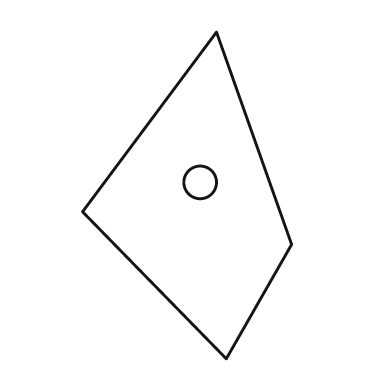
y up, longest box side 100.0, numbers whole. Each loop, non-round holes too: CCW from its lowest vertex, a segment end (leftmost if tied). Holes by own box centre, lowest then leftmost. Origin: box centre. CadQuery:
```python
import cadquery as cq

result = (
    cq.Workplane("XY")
    .moveTo(12.0, -50.0)
    .lineTo(32.0, -15.0)
    .lineTo(9.0, 50.0)
    .lineTo(-32.0, -5.0)
    .close()
    .moveTo(4.0, 4.0)
    .circle(5.0)
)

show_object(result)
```